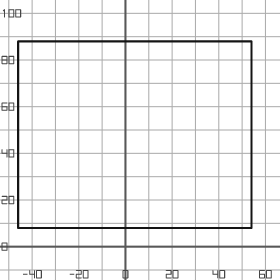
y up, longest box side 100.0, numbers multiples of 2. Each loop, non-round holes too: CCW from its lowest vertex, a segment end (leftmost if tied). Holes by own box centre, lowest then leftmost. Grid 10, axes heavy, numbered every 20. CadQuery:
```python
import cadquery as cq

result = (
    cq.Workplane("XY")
    .moveTo(-46.0, 8.0)
    .lineTo(54.0, 8.0)
    .lineTo(54.0, 88.0)
    .lineTo(-46.0, 88.0)
    .close()
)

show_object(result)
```